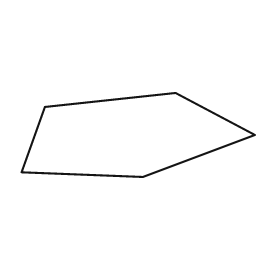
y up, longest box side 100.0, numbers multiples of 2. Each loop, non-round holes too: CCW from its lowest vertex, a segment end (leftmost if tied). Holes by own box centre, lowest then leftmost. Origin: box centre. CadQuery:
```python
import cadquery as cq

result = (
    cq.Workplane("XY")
    .moveTo(2.0, -18.0)
    .lineTo(50.0, 0.0)
    .lineTo(16.0, 18.0)
    .lineTo(-40.0, 12.0)
    .lineTo(-50.0, -16.0)
    .close()
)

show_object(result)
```